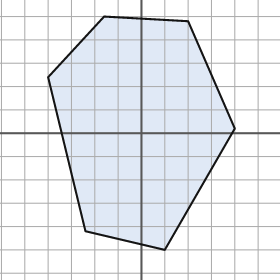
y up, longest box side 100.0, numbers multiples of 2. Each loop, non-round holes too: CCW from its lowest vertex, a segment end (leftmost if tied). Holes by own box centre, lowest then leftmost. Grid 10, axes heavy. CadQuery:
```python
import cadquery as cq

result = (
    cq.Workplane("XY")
    .moveTo(10.0, -50.0)
    .lineTo(40.0, 2.0)
    .lineTo(20.0, 48.0)
    .lineTo(-16.0, 50.0)
    .lineTo(-40.0, 24.0)
    .lineTo(-24.0, -42.0)
    .close()
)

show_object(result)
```